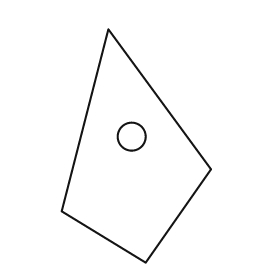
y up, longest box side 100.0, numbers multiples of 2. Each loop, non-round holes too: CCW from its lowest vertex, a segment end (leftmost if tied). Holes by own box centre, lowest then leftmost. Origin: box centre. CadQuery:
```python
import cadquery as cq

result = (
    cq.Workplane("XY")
    .moveTo(4.0, -50.0)
    .lineTo(32.0, -10.0)
    .lineTo(-12.0, 50.0)
    .lineTo(-32.0, -28.0)
    .close()
    .moveTo(-2.0, 4.0)
    .circle(6.0)
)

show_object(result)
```